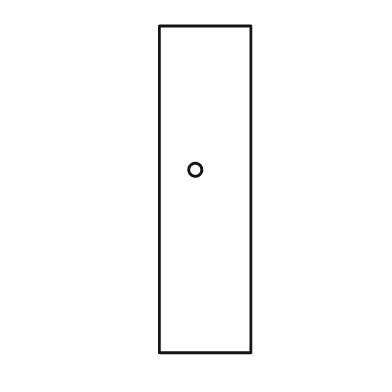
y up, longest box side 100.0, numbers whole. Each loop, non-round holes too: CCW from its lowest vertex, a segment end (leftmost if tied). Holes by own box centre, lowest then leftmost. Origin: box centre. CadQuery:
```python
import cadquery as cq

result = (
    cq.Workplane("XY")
    .moveTo(-14.0, -50.0)
    .lineTo(14.0, -50.0)
    .lineTo(14.0, 50.0)
    .lineTo(-14.0, 50.0)
    .close()
    .moveTo(-3.0, 6.0)
    .circle(2.0)
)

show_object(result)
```